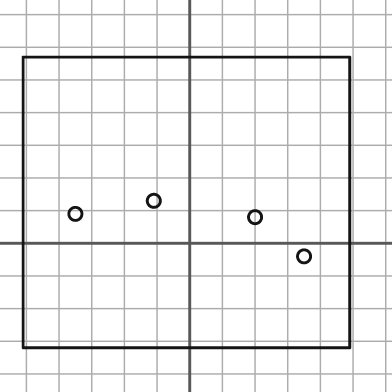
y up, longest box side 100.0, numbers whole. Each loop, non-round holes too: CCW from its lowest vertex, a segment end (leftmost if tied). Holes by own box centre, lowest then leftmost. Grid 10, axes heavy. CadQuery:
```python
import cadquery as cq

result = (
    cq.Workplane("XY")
    .moveTo(-51.0, -32.0)
    .lineTo(49.0, -32.0)
    .lineTo(49.0, 57.0)
    .lineTo(-51.0, 57.0)
    .close()
    .moveTo(35.0, -4.0)
    .circle(2.0)
    .moveTo(20.0, 8.0)
    .circle(2.0)
    .moveTo(-35.0, 9.0)
    .circle(2.0)
    .moveTo(-11.0, 13.0)
    .circle(2.0)
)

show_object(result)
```